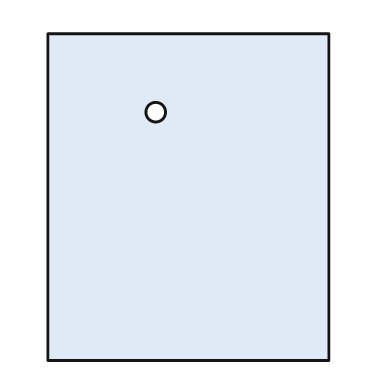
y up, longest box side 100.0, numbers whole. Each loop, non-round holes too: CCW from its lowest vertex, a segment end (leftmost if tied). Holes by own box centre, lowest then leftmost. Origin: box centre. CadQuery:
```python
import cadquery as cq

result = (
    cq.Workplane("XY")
    .moveTo(-43.0, -50.0)
    .lineTo(43.0, -50.0)
    .lineTo(43.0, 50.0)
    .lineTo(-43.0, 50.0)
    .close()
    .moveTo(-10.0, 26.0)
    .circle(3.0)
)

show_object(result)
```